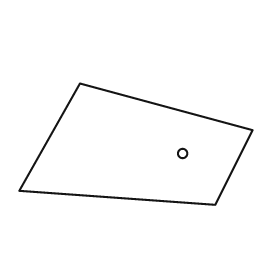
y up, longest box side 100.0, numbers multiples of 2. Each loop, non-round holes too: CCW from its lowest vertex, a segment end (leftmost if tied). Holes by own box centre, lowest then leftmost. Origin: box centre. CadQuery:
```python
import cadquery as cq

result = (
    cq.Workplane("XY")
    .moveTo(34.0, -26.0)
    .lineTo(50.0, 6.0)
    .lineTo(-24.0, 26.0)
    .lineTo(-50.0, -20.0)
    .close()
    .moveTo(20.0, -4.0)
    .circle(2.0)
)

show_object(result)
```